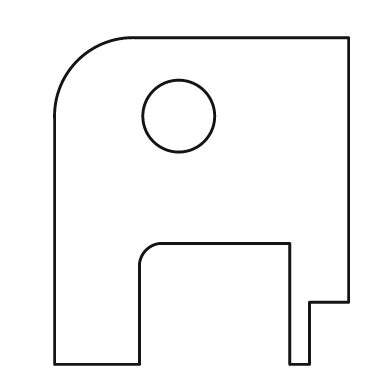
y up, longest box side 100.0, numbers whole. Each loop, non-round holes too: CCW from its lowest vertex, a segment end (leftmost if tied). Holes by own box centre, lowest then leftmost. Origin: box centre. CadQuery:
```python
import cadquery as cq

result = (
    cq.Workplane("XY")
    .moveTo(-45.0, -50.0)
    .lineTo(-19.0, -50.0)
    .lineTo(-19.0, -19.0)
    .threePointArc((-17.0, -15.0), (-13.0, -13.0))
    .lineTo(27.0, -13.0)
    .lineTo(27.0, -50.0)
    .lineTo(33.0, -50.0)
    .lineTo(33.0, -31.0)
    .lineTo(45.0, -31.0)
    .lineTo(45.0, 50.0)
    .lineTo(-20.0, 50.0)
    .threePointArc((-38.0, 43.0), (-45.0, 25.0))
    .close()
    .moveTo(-7.0, 26.0)
    .circle(11.0)
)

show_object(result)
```